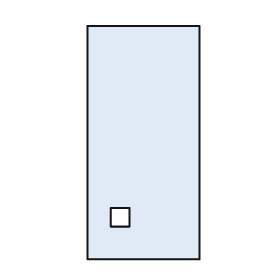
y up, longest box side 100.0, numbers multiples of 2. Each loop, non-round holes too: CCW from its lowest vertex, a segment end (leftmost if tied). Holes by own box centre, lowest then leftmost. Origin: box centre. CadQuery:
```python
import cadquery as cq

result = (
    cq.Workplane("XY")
    .moveTo(-24.0, -50.0)
    .lineTo(24.0, -50.0)
    .lineTo(24.0, 50.0)
    .lineTo(-24.0, 50.0)
    .close()
    .moveTo(-14.0, -36.0)
    .lineTo(-6.0, -36.0)
    .lineTo(-6.0, -28.0)
    .lineTo(-14.0, -28.0)
    .close()
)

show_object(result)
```